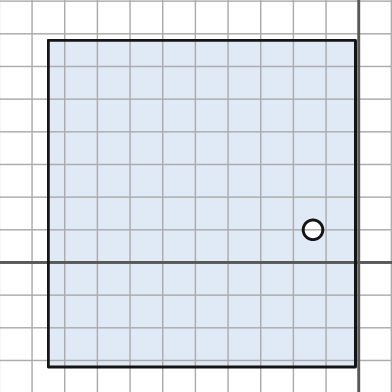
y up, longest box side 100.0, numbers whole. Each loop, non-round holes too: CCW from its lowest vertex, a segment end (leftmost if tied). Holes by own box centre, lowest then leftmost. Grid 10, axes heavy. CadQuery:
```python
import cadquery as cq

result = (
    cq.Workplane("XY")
    .moveTo(-95.0, -32.0)
    .lineTo(-1.0, -32.0)
    .lineTo(-1.0, 68.0)
    .lineTo(-95.0, 68.0)
    .close()
    .moveTo(-14.0, 10.0)
    .circle(3.0)
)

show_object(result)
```